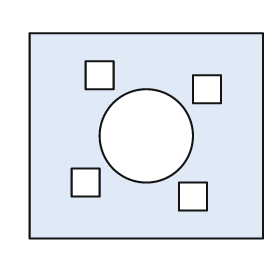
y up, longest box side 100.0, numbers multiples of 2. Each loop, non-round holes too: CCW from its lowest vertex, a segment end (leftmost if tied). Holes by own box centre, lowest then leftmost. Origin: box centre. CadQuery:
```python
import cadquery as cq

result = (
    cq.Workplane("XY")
    .moveTo(-50.0, -44.0)
    .lineTo(50.0, -44.0)
    .lineTo(50.0, 44.0)
    .lineTo(-50.0, 44.0)
    .close()
    .moveTo(14.0, -32.0)
    .lineTo(26.0, -32.0)
    .lineTo(26.0, -20.0)
    .lineTo(14.0, -20.0)
    .close()
    .moveTo(-32.0, -26.0)
    .lineTo(-20.0, -26.0)
    .lineTo(-20.0, -14.0)
    .lineTo(-32.0, -14.0)
    .close()
    .moveTo(0.0, 0.0)
    .circle(20.0)
    .moveTo(20.0, 14.0)
    .lineTo(32.0, 14.0)
    .lineTo(32.0, 26.0)
    .lineTo(20.0, 26.0)
    .close()
    .moveTo(-26.0, 20.0)
    .lineTo(-14.0, 20.0)
    .lineTo(-14.0, 32.0)
    .lineTo(-26.0, 32.0)
    .close()
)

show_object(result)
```